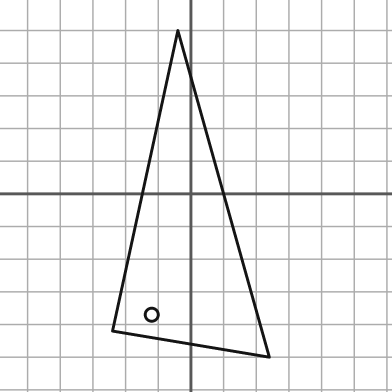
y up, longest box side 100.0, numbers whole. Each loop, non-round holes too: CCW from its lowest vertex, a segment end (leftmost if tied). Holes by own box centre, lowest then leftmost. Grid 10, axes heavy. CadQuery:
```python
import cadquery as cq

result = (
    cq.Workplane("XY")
    .moveTo(24.0, -50.0)
    .lineTo(-4.0, 50.0)
    .lineTo(-24.0, -42.0)
    .close()
    .moveTo(-12.0, -37.0)
    .circle(2.0)
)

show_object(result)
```